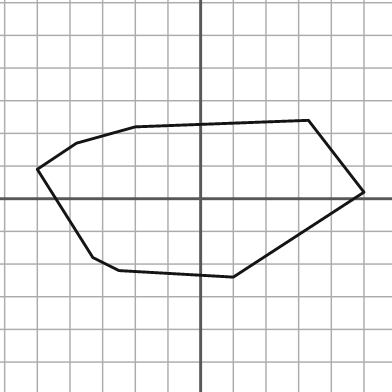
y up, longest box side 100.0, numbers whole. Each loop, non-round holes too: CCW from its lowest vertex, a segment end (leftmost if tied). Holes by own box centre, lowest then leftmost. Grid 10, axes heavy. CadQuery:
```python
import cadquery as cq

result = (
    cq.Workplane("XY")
    .moveTo(10.0, -24.0)
    .lineTo(50.0, 2.0)
    .lineTo(33.0, 24.0)
    .lineTo(-20.0, 22.0)
    .lineTo(-38.0, 17.0)
    .lineTo(-50.0, 9.0)
    .lineTo(-33.0, -18.0)
    .lineTo(-25.0, -22.0)
    .close()
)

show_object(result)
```